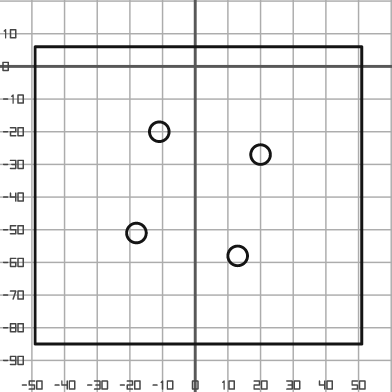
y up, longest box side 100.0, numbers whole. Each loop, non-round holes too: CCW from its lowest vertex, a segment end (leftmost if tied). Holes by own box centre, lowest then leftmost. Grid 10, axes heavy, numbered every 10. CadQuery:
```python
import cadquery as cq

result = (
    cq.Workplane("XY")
    .moveTo(-49.0, -85.0)
    .lineTo(51.0, -85.0)
    .lineTo(51.0, 6.0)
    .lineTo(-49.0, 6.0)
    .close()
    .moveTo(13.0, -58.0)
    .circle(3.0)
    .moveTo(-18.0, -51.0)
    .circle(3.0)
    .moveTo(20.0, -27.0)
    .circle(3.0)
    .moveTo(-11.0, -20.0)
    .circle(3.0)
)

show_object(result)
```